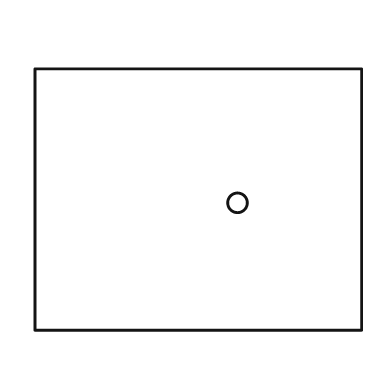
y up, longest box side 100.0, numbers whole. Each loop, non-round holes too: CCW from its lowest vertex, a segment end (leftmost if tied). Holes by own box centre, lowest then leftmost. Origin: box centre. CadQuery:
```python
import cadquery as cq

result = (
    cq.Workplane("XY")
    .moveTo(-50.0, -40.0)
    .lineTo(50.0, -40.0)
    .lineTo(50.0, 40.0)
    .lineTo(-50.0, 40.0)
    .close()
    .moveTo(12.0, -1.0)
    .circle(3.0)
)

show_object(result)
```